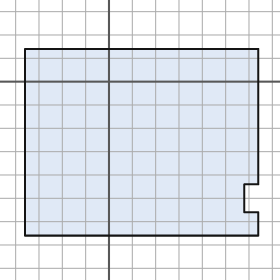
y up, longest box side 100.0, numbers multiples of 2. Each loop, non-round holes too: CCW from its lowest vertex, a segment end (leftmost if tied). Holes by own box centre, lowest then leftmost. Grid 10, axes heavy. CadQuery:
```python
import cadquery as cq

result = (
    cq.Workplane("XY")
    .moveTo(-36.0, -66.0)
    .lineTo(64.0, -66.0)
    .lineTo(64.0, -56.0)
    .lineTo(58.0, -56.0)
    .lineTo(58.0, -44.0)
    .lineTo(64.0, -44.0)
    .lineTo(64.0, 14.0)
    .lineTo(-36.0, 14.0)
    .close()
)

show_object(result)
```